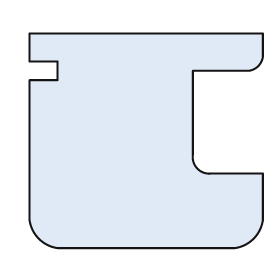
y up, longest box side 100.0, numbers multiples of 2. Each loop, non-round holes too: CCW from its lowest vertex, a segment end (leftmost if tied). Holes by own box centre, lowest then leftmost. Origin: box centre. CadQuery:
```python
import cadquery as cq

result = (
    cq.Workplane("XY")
    .moveTo(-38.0, -46.0)
    .lineTo(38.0, -46.0)
    .threePointArc((46.0, -42.0), (50.0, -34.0))
    .lineTo(50.0, -14.0)
    .lineTo(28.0, -14.0)
    .threePointArc((22.0, -12.0), (20.0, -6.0))
    .lineTo(20.0, 30.0)
    .lineTo(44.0, 30.0)
    .threePointArc((48.0, 32.0), (50.0, 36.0))
    .lineTo(50.0, 46.0)
    .lineTo(-50.0, 46.0)
    .lineTo(-50.0, 34.0)
    .lineTo(-38.0, 34.0)
    .lineTo(-38.0, 26.0)
    .lineTo(-50.0, 26.0)
    .lineTo(-50.0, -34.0)
    .threePointArc((-46.0, -42.0), (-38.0, -46.0))
    .close()
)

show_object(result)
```